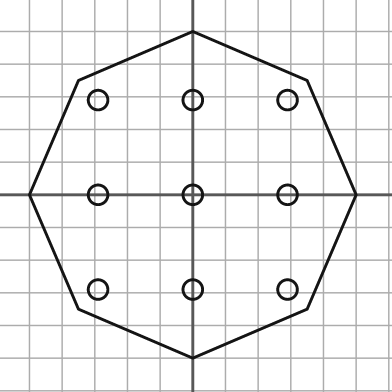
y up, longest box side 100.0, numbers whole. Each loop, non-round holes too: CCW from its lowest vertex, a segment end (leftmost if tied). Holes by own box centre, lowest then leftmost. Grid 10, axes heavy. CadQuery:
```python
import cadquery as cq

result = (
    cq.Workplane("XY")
    .moveTo(0.0, -50.0)
    .lineTo(35.0, -35.0)
    .lineTo(50.0, 0.0)
    .lineTo(35.0, 35.0)
    .lineTo(0.0, 50.0)
    .lineTo(-35.0, 35.0)
    .lineTo(-50.0, 0.0)
    .lineTo(-35.0, -35.0)
    .close()
    .moveTo(-29.0, -29.0)
    .circle(3.0)
    .moveTo(0.0, -29.0)
    .circle(3.0)
    .moveTo(29.0, -29.0)
    .circle(3.0)
    .moveTo(-29.0, 0.0)
    .circle(3.0)
    .moveTo(0.0, 0.0)
    .circle(3.0)
    .moveTo(29.0, 0.0)
    .circle(3.0)
    .moveTo(-29.0, 29.0)
    .circle(3.0)
    .moveTo(0.0, 29.0)
    .circle(3.0)
    .moveTo(29.0, 29.0)
    .circle(3.0)
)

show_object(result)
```